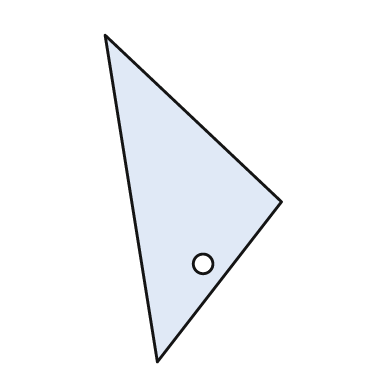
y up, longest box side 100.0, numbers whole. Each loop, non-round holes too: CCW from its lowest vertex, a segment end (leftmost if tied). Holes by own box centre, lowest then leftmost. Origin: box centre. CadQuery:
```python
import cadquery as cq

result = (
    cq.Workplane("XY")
    .moveTo(-11.0, -50.0)
    .lineTo(27.0, -1.0)
    .lineTo(-27.0, 50.0)
    .close()
    .moveTo(3.0, -20.0)
    .circle(3.0)
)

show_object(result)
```